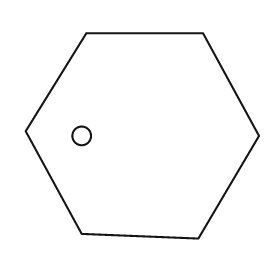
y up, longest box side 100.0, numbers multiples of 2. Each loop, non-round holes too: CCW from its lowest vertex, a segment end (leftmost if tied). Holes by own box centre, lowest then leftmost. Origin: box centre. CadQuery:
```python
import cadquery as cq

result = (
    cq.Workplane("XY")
    .moveTo(24.0, -44.0)
    .lineTo(50.0, 0.0)
    .lineTo(26.0, 44.0)
    .lineTo(-24.0, 44.0)
    .lineTo(-50.0, 2.0)
    .lineTo(-26.0, -42.0)
    .close()
    .moveTo(-26.0, 0.0)
    .circle(4.0)
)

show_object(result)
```